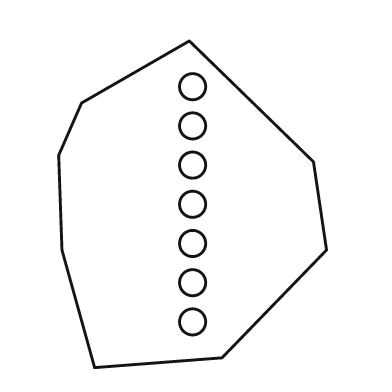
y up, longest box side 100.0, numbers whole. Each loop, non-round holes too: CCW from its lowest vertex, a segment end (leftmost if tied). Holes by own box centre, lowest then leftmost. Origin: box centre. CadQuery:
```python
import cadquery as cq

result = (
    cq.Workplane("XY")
    .moveTo(-30.0, -50.0)
    .lineTo(9.0, -47.0)
    .lineTo(41.0, -14.0)
    .lineTo(37.0, 13.0)
    .lineTo(-1.0, 50.0)
    .lineTo(-34.0, 31.0)
    .lineTo(-41.0, 15.0)
    .lineTo(-40.0, -14.0)
    .close()
    .moveTo(0.0, -36.0)
    .circle(4.0)
    .moveTo(0.0, -24.0)
    .circle(4.0)
    .moveTo(0.0, -12.0)
    .circle(4.0)
    .moveTo(0.0, 0.0)
    .circle(4.0)
    .moveTo(0.0, 12.0)
    .circle(4.0)
    .moveTo(0.0, 24.0)
    .circle(4.0)
    .moveTo(0.0, 36.0)
    .circle(4.0)
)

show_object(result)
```